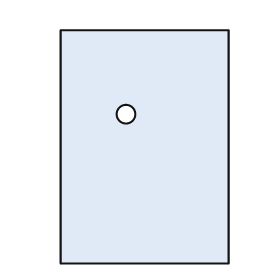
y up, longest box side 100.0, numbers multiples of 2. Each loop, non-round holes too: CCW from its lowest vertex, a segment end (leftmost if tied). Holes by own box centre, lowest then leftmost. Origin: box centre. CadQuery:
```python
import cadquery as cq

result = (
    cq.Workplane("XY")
    .moveTo(-36.0, -50.0)
    .lineTo(36.0, -50.0)
    .lineTo(36.0, 50.0)
    .lineTo(-36.0, 50.0)
    .close()
    .moveTo(-8.0, 14.0)
    .circle(4.0)
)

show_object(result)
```